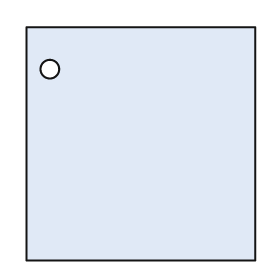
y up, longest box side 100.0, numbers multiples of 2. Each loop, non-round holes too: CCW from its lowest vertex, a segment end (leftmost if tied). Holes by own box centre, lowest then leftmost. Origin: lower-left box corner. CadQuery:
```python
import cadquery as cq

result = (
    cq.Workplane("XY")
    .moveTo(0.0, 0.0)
    .lineTo(98.0, 0.0)
    .lineTo(98.0, 100.0)
    .lineTo(0.0, 100.0)
    .close()
    .moveTo(10.0, 82.0)
    .circle(4.0)
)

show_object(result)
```